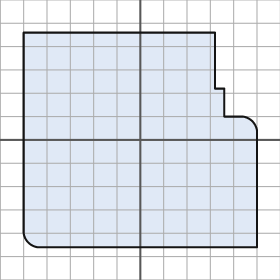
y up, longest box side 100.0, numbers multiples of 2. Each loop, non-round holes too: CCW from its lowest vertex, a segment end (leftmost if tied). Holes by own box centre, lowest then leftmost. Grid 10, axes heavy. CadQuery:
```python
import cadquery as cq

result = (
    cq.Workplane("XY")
    .moveTo(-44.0, -46.0)
    .lineTo(50.0, -46.0)
    .lineTo(50.0, 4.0)
    .threePointArc((48.0, 8.0), (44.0, 10.0))
    .lineTo(36.0, 10.0)
    .lineTo(36.0, 22.0)
    .lineTo(32.0, 22.0)
    .lineTo(32.0, 46.0)
    .lineTo(-50.0, 46.0)
    .lineTo(-50.0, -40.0)
    .threePointArc((-48.0, -44.0), (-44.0, -46.0))
    .close()
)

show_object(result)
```